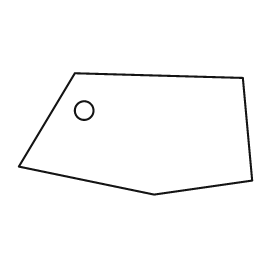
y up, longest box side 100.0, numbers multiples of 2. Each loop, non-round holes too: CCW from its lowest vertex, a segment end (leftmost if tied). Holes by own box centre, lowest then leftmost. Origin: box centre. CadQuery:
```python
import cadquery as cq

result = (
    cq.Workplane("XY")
    .moveTo(8.0, -26.0)
    .lineTo(50.0, -20.0)
    .lineTo(46.0, 24.0)
    .lineTo(-26.0, 26.0)
    .lineTo(-50.0, -14.0)
    .close()
    .moveTo(-22.0, 10.0)
    .circle(4.0)
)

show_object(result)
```